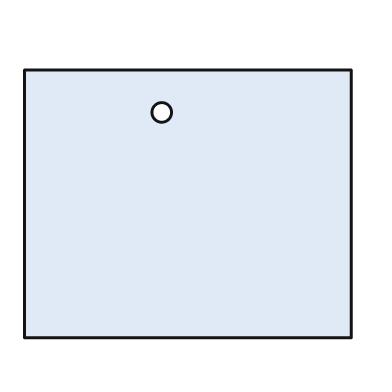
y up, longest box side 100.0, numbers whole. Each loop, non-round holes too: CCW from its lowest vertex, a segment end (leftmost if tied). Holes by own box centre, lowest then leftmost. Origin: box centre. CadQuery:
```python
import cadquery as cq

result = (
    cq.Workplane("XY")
    .moveTo(-50.0, -41.0)
    .lineTo(50.0, -41.0)
    .lineTo(50.0, 41.0)
    .lineTo(-50.0, 41.0)
    .close()
    .moveTo(-8.0, 28.0)
    .circle(3.0)
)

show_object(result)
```